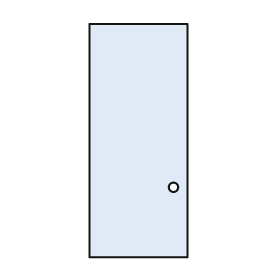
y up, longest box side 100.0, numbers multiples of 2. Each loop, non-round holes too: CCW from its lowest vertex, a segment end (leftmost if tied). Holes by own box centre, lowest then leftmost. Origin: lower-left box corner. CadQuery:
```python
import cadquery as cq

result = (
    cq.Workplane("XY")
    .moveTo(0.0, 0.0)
    .lineTo(42.0, 0.0)
    .lineTo(42.0, 100.0)
    .lineTo(0.0, 100.0)
    .close()
    .moveTo(36.0, 30.0)
    .circle(2.0)
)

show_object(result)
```